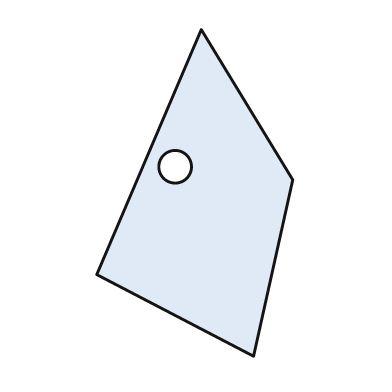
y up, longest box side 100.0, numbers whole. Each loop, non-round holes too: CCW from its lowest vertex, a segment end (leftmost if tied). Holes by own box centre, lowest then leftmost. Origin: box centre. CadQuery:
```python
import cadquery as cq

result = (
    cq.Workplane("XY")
    .moveTo(18.0, -50.0)
    .lineTo(30.0, 4.0)
    .lineTo(2.0, 50.0)
    .lineTo(-30.0, -25.0)
    .close()
    .moveTo(-6.0, 8.0)
    .circle(5.0)
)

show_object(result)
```